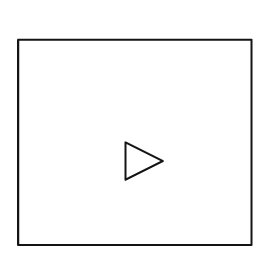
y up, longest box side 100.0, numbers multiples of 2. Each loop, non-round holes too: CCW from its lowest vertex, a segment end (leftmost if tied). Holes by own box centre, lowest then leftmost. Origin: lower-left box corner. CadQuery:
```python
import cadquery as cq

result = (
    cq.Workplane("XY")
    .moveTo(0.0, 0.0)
    .lineTo(100.0, 0.0)
    .lineTo(100.0, 88.0)
    .lineTo(0.0, 88.0)
    .close()
    .moveTo(46.0, 28.0)
    .lineTo(62.0, 36.0)
    .lineTo(46.0, 44.0)
    .close()
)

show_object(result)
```